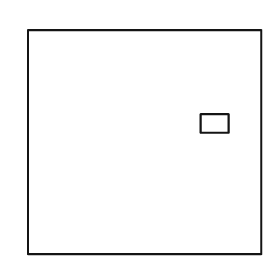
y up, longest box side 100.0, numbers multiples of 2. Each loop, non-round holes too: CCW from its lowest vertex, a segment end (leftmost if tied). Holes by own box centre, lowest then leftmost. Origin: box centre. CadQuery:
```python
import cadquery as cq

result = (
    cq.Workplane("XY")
    .moveTo(-50.0, -48.0)
    .lineTo(50.0, -48.0)
    .lineTo(50.0, 48.0)
    .lineTo(-50.0, 48.0)
    .close()
    .moveTo(24.0, 4.0)
    .lineTo(36.0, 4.0)
    .lineTo(36.0, 12.0)
    .lineTo(24.0, 12.0)
    .close()
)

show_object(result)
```